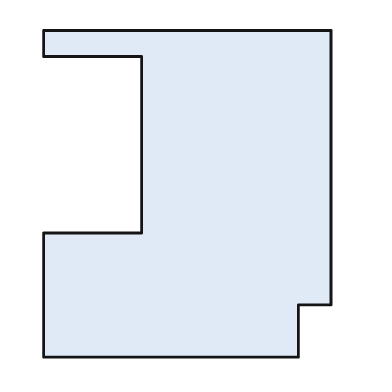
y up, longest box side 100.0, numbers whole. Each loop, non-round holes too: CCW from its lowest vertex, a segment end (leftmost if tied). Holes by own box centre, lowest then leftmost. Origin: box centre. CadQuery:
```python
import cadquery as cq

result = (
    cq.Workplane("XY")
    .moveTo(-44.0, -50.0)
    .lineTo(34.0, -50.0)
    .lineTo(34.0, -34.0)
    .lineTo(44.0, -34.0)
    .lineTo(44.0, 50.0)
    .lineTo(-44.0, 50.0)
    .lineTo(-44.0, 42.0)
    .lineTo(-14.0, 42.0)
    .lineTo(-14.0, -12.0)
    .lineTo(-44.0, -12.0)
    .close()
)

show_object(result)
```